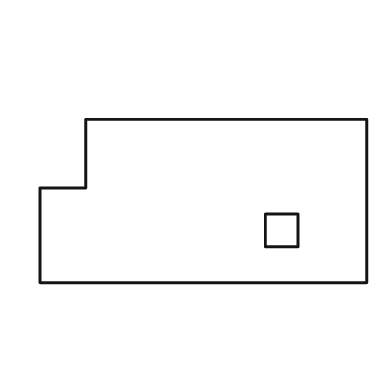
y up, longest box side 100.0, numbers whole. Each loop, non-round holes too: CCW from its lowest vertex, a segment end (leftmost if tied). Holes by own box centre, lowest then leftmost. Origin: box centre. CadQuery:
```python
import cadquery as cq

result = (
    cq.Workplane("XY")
    .moveTo(-50.0, -25.0)
    .lineTo(50.0, -25.0)
    .lineTo(50.0, 25.0)
    .lineTo(-36.0, 25.0)
    .lineTo(-36.0, 4.0)
    .lineTo(-50.0, 4.0)
    .close()
    .moveTo(19.0, -14.0)
    .lineTo(29.0, -14.0)
    .lineTo(29.0, -4.0)
    .lineTo(19.0, -4.0)
    .close()
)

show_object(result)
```